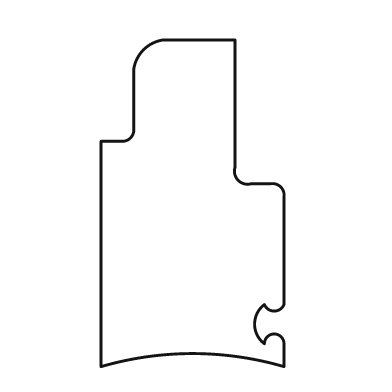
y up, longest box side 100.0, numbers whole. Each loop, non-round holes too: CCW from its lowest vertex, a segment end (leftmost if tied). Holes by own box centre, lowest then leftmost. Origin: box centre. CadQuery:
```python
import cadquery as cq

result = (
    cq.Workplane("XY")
    .moveTo(-28.0, -50.0)
    .threePointArc((0.0, -46.0), (28.0, -50.0))
    .lineTo(28.0, -43.0)
    .threePointArc((25.0, -40.0), (22.0, -43.0))
    .threePointArc((19.0, -37.0), (22.0, -31.0))
    .threePointArc((25.0, -33.0), (28.0, -31.0))
    .lineTo(28.0, 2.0)
    .threePointArc((27.0, 5.0), (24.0, 6.0))
    .lineTo(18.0, 6.0)
    .threePointArc((14.0, 7.0), (13.0, 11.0))
    .lineTo(13.0, 50.0)
    .lineTo(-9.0, 50.0)
    .threePointArc((-15.0, 47.0), (-18.0, 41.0))
    .lineTo(-18.0, 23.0)
    .threePointArc((-19.0, 20.0), (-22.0, 19.0))
    .lineTo(-28.0, 19.0)
    .close()
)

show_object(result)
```